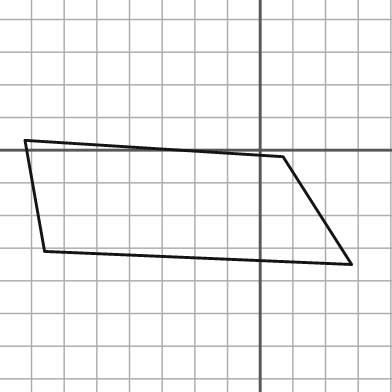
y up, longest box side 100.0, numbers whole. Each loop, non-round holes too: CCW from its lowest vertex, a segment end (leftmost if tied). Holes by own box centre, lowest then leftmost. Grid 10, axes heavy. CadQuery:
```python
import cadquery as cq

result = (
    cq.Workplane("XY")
    .moveTo(28.0, -35.0)
    .lineTo(7.0, -2.0)
    .lineTo(-72.0, 3.0)
    .lineTo(-66.0, -31.0)
    .close()
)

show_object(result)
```